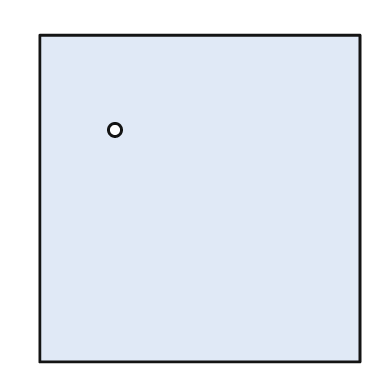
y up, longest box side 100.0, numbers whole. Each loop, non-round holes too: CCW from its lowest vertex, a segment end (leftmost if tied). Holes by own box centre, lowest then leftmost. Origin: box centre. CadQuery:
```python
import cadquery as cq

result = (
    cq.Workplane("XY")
    .moveTo(-49.0, -50.0)
    .lineTo(49.0, -50.0)
    .lineTo(49.0, 50.0)
    .lineTo(-49.0, 50.0)
    .close()
    .moveTo(-26.0, 21.0)
    .circle(2.0)
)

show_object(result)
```